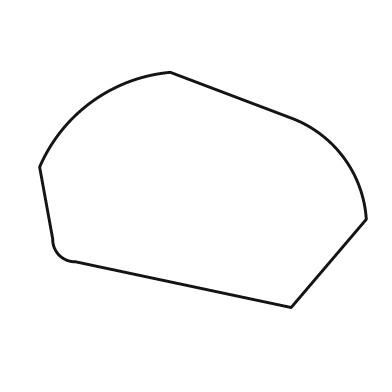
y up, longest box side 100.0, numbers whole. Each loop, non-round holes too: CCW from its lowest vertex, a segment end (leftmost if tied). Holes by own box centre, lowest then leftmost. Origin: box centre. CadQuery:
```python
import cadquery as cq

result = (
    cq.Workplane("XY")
    .moveTo(27.0, -36.0)
    .lineTo(50.0, -9.0)
    .threePointArc((43.0, 10.0), (27.0, 22.0))
    .lineTo(-10.0, 36.0)
    .threePointArc((-34.0, 27.0), (-50.0, 7.0))
    .lineTo(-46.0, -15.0)
    .threePointArc((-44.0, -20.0), (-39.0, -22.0))
    .close()
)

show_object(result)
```